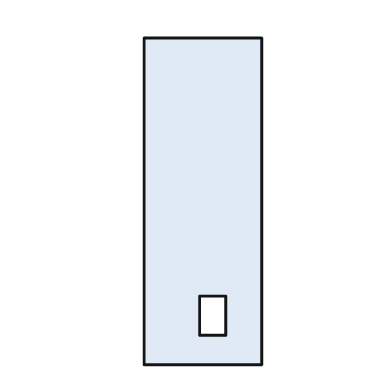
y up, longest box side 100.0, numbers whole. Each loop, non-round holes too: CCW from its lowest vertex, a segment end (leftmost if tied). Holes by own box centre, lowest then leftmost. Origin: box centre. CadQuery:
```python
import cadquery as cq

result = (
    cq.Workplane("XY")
    .moveTo(-18.0, -50.0)
    .lineTo(18.0, -50.0)
    .lineTo(18.0, 50.0)
    .lineTo(-18.0, 50.0)
    .close()
    .moveTo(-1.0, -41.0)
    .lineTo(7.0, -41.0)
    .lineTo(7.0, -29.0)
    .lineTo(-1.0, -29.0)
    .close()
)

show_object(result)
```